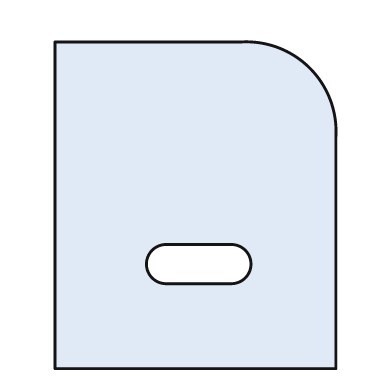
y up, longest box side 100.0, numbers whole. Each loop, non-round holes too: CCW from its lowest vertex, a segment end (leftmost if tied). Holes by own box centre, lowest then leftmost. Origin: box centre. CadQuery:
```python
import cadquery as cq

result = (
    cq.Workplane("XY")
    .moveTo(-43.0, -50.0)
    .lineTo(43.0, -50.0)
    .lineTo(43.0, 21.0)
    .threePointArc((35.0, 42.0), (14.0, 50.0))
    .lineTo(-43.0, 50.0)
    .close()
    .moveTo(-9.0, -24.0)
    .lineTo(11.0, -24.0)
    .threePointArc((17.0, -18.0), (11.0, -12.0))
    .lineTo(-9.0, -12.0)
    .threePointArc((-15.0, -18.0), (-9.0, -24.0))
    .close()
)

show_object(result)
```